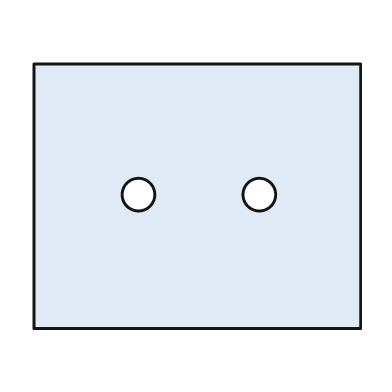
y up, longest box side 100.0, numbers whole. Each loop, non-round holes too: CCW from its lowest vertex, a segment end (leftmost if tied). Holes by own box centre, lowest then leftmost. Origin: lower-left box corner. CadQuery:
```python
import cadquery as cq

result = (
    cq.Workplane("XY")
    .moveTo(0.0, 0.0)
    .lineTo(100.0, 0.0)
    .lineTo(100.0, 81.0)
    .lineTo(0.0, 81.0)
    .close()
    .moveTo(32.0, 41.0)
    .circle(5.0)
    .moveTo(69.0, 41.0)
    .circle(5.0)
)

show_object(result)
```